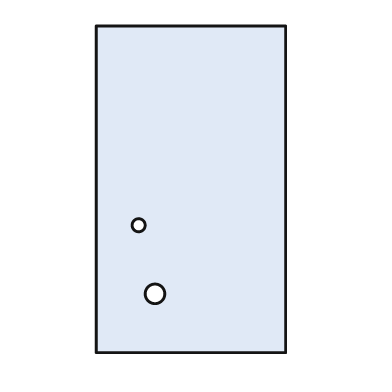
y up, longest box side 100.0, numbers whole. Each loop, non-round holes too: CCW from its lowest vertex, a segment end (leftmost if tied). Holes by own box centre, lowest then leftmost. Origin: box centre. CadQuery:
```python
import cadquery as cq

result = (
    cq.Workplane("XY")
    .moveTo(-29.0, -50.0)
    .lineTo(29.0, -50.0)
    .lineTo(29.0, 50.0)
    .lineTo(-29.0, 50.0)
    .close()
    .moveTo(-11.0, -32.0)
    .circle(3.0)
    .moveTo(-16.0, -11.0)
    .circle(2.0)
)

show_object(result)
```